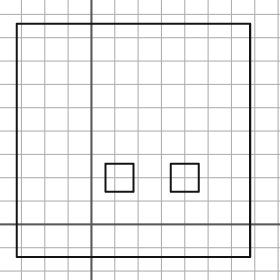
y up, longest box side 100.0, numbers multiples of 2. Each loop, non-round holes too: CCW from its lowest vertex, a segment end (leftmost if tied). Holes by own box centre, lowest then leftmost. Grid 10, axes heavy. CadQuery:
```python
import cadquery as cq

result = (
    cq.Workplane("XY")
    .moveTo(-32.0, -14.0)
    .lineTo(68.0, -14.0)
    .lineTo(68.0, 86.0)
    .lineTo(-32.0, 86.0)
    .close()
    .moveTo(6.0, 14.0)
    .lineTo(18.0, 14.0)
    .lineTo(18.0, 26.0)
    .lineTo(6.0, 26.0)
    .close()
    .moveTo(34.0, 14.0)
    .lineTo(46.0, 14.0)
    .lineTo(46.0, 26.0)
    .lineTo(34.0, 26.0)
    .close()
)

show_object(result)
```